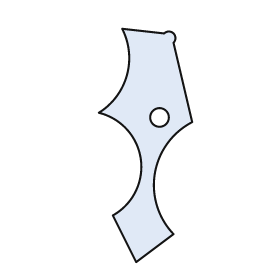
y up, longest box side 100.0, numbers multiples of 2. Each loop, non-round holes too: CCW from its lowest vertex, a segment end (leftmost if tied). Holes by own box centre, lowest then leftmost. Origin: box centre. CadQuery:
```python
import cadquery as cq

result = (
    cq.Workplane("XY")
    .moveTo(-4.0, -50.0)
    .lineTo(12.0, -38.0)
    .threePointArc((4.0, -12.0), (20.0, 10.0))
    .lineTo(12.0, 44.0)
    .threePointArc((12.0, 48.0), (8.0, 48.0))
    .lineTo(-10.0, 50.0)
    .threePointArc((-8.0, 30.0), (-20.0, 14.0))
    .threePointArc((-2.0, -6.0), (-14.0, -30.0))
    .close()
    .moveTo(6.0, 12.0)
    .circle(4.0)
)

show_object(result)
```